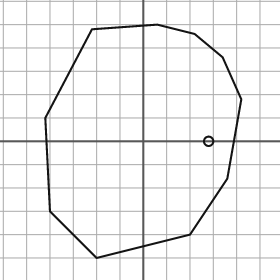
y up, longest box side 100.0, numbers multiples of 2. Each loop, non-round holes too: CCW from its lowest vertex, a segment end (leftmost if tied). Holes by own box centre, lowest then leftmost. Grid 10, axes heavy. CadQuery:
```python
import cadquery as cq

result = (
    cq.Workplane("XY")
    .moveTo(-20.0, -50.0)
    .lineTo(20.0, -40.0)
    .lineTo(36.0, -16.0)
    .lineTo(42.0, 18.0)
    .lineTo(34.0, 36.0)
    .lineTo(22.0, 46.0)
    .lineTo(6.0, 50.0)
    .lineTo(-22.0, 48.0)
    .lineTo(-42.0, 10.0)
    .lineTo(-40.0, -30.0)
    .close()
    .moveTo(28.0, 0.0)
    .circle(2.0)
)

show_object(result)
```